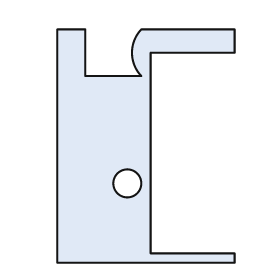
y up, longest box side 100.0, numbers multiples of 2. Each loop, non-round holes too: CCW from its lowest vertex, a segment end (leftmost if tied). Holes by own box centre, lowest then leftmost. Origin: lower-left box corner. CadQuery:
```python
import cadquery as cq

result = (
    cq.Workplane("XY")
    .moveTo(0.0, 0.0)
    .lineTo(76.0, 0.0)
    .lineTo(76.0, 4.0)
    .lineTo(40.0, 4.0)
    .lineTo(40.0, 90.0)
    .lineTo(76.0, 90.0)
    .lineTo(76.0, 100.0)
    .lineTo(36.0, 100.0)
    .threePointArc((32.0, 90.0), (36.0, 80.0))
    .lineTo(12.0, 80.0)
    .lineTo(12.0, 100.0)
    .lineTo(0.0, 100.0)
    .close()
    .moveTo(30.0, 34.0)
    .circle(6.0)
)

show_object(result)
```